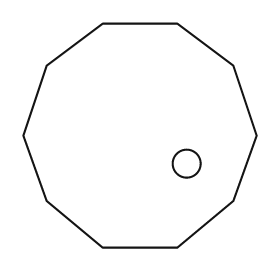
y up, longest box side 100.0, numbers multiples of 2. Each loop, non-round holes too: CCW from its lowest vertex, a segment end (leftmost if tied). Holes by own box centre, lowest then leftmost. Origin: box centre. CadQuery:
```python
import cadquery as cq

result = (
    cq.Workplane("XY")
    .moveTo(-16.0, -48.0)
    .lineTo(16.0, -48.0)
    .lineTo(40.0, -28.0)
    .lineTo(50.0, 0.0)
    .lineTo(40.0, 30.0)
    .lineTo(16.0, 48.0)
    .lineTo(-16.0, 48.0)
    .lineTo(-40.0, 30.0)
    .lineTo(-50.0, 0.0)
    .lineTo(-40.0, -28.0)
    .close()
    .moveTo(20.0, -12.0)
    .circle(6.0)
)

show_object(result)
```